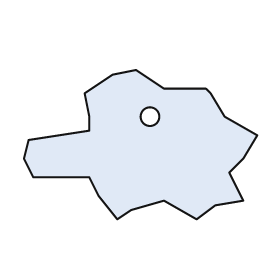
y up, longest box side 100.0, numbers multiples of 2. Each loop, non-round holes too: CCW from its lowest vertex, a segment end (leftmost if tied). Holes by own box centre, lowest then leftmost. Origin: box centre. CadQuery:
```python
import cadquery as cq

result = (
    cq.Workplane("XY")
    .moveTo(-10.0, -32.0)
    .lineTo(-4.0, -28.0)
    .lineTo(10.0, -24.0)
    .lineTo(24.0, -32.0)
    .lineTo(32.0, -26.0)
    .lineTo(44.0, -24.0)
    .lineTo(38.0, -12.0)
    .lineTo(44.0, -6.0)
    .lineTo(50.0, 4.0)
    .lineTo(36.0, 12.0)
    .lineTo(30.0, 22.0)
    .lineTo(28.0, 24.0)
    .lineTo(10.0, 24.0)
    .lineTo(-2.0, 32.0)
    .lineTo(-12.0, 30.0)
    .lineTo(-24.0, 22.0)
    .lineTo(-22.0, 12.0)
    .lineTo(-22.0, 6.0)
    .lineTo(-48.0, 2.0)
    .lineTo(-50.0, -6.0)
    .lineTo(-46.0, -14.0)
    .lineTo(-22.0, -14.0)
    .lineTo(-18.0, -22.0)
    .close()
    .moveTo(4.0, 12.0)
    .circle(4.0)
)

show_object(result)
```